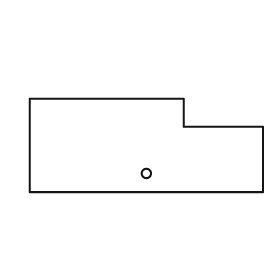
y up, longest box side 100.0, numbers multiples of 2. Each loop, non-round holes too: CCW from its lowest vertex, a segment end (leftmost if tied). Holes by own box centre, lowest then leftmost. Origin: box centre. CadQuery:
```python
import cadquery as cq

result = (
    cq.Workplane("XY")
    .moveTo(-50.0, -20.0)
    .lineTo(50.0, -20.0)
    .lineTo(50.0, 8.0)
    .lineTo(16.0, 8.0)
    .lineTo(16.0, 20.0)
    .lineTo(-50.0, 20.0)
    .close()
    .moveTo(0.0, -12.0)
    .circle(2.0)
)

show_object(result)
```